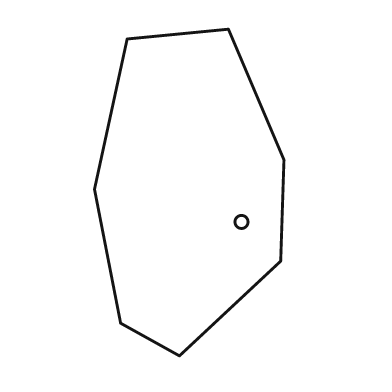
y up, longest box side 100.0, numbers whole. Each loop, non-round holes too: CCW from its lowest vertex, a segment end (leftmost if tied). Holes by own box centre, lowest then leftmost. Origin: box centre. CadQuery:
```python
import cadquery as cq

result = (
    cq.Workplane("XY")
    .moveTo(-3.0, -50.0)
    .lineTo(28.0, -21.0)
    .lineTo(29.0, 10.0)
    .lineTo(12.0, 50.0)
    .lineTo(-19.0, 47.0)
    .lineTo(-29.0, 1.0)
    .lineTo(-21.0, -40.0)
    .close()
    .moveTo(16.0, -9.0)
    .circle(2.0)
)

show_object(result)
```